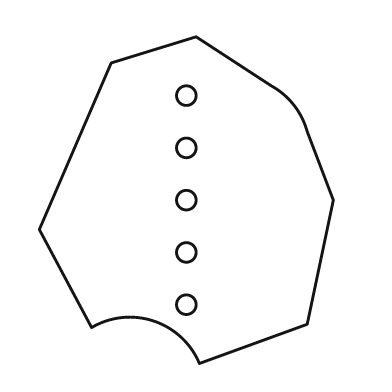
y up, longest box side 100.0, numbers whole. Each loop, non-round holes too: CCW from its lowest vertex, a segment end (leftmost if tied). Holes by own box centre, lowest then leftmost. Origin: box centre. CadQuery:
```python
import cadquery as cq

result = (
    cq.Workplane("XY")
    .moveTo(4.0, -50.0)
    .lineTo(37.0, -38.0)
    .lineTo(45.0, 0.0)
    .lineTo(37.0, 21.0)
    .threePointArc((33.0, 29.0), (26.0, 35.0))
    .lineTo(3.0, 50.0)
    .lineTo(-23.0, 42.0)
    .lineTo(-45.0, -9.0)
    .lineTo(-29.0, -39.0)
    .threePointArc((-10.0, -37.0), (4.0, -50.0))
    .close()
    .moveTo(0.0, -32.0)
    .circle(3.0)
    .moveTo(0.0, -16.0)
    .circle(3.0)
    .moveTo(0.0, 0.0)
    .circle(3.0)
    .moveTo(0.0, 16.0)
    .circle(3.0)
    .moveTo(0.0, 32.0)
    .circle(3.0)
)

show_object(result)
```